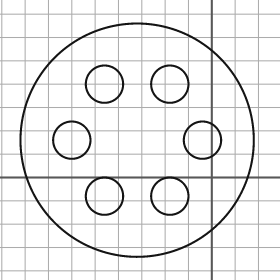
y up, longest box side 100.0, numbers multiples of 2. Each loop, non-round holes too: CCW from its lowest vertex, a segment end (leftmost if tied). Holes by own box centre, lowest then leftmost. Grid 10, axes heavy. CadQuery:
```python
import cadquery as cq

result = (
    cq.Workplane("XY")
    .moveTo(-32.0, 16.0)
    .circle(50.0)
    .moveTo(-46.0, -8.0)
    .circle(8.0)
    .moveTo(-18.0, -8.0)
    .circle(8.0)
    .moveTo(-60.0, 16.0)
    .circle(8.0)
    .moveTo(-4.0, 16.0)
    .circle(8.0)
    .moveTo(-46.0, 40.0)
    .circle(8.0)
    .moveTo(-18.0, 40.0)
    .circle(8.0)
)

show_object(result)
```